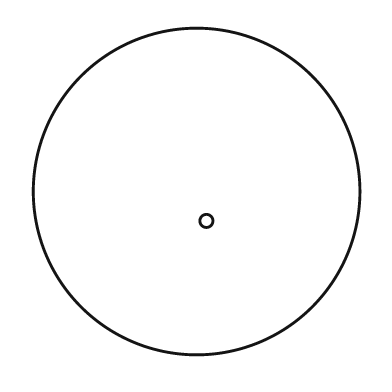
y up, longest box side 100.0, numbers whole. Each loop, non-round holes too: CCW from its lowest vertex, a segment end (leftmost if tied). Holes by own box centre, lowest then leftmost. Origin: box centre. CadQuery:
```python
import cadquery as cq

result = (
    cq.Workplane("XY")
    .moveTo(0.0, 0.0)
    .circle(50.0)
    .moveTo(3.0, -9.0)
    .circle(2.0)
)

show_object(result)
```